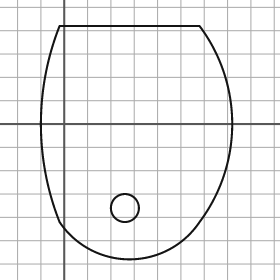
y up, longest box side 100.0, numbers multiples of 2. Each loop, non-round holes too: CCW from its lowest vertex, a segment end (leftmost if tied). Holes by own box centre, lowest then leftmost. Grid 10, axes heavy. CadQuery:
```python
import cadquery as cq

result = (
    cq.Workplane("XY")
    .moveTo(-2.0, -42.0)
    .threePointArc((28.0, -58.0), (58.0, -42.0))
    .threePointArc((72.0, 0.0), (58.0, 42.0))
    .lineTo(-2.0, 42.0)
    .threePointArc((-10.0, 0.0), (-2.0, -42.0))
    .close()
    .moveTo(26.0, -36.0)
    .circle(6.0)
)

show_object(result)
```